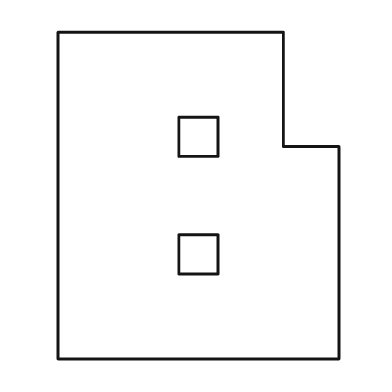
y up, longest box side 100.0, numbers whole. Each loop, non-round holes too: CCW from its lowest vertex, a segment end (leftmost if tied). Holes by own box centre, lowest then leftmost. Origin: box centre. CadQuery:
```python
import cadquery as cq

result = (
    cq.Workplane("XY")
    .moveTo(-43.0, -50.0)
    .lineTo(43.0, -50.0)
    .lineTo(43.0, 15.0)
    .lineTo(26.0, 15.0)
    .lineTo(26.0, 50.0)
    .lineTo(-43.0, 50.0)
    .close()
    .moveTo(-6.0, -24.0)
    .lineTo(6.0, -24.0)
    .lineTo(6.0, -12.0)
    .lineTo(-6.0, -12.0)
    .close()
    .moveTo(-6.0, 12.0)
    .lineTo(6.0, 12.0)
    .lineTo(6.0, 24.0)
    .lineTo(-6.0, 24.0)
    .close()
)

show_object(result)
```